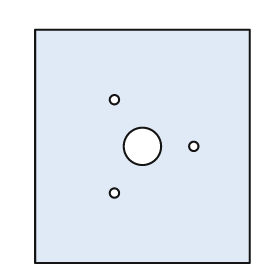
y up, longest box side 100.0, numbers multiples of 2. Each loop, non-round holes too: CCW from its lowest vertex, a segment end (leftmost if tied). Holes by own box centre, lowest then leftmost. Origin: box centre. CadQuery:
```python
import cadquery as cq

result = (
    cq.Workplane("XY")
    .moveTo(-46.0, -50.0)
    .lineTo(46.0, -50.0)
    .lineTo(46.0, 50.0)
    .lineTo(-46.0, 50.0)
    .close()
    .moveTo(-12.0, -20.0)
    .circle(2.0)
    .moveTo(0.0, 0.0)
    .circle(8.0)
    .moveTo(22.0, 0.0)
    .circle(2.0)
    .moveTo(-12.0, 20.0)
    .circle(2.0)
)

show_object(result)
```